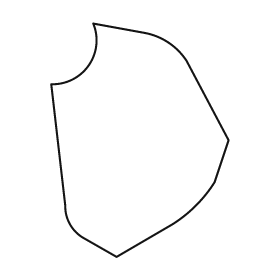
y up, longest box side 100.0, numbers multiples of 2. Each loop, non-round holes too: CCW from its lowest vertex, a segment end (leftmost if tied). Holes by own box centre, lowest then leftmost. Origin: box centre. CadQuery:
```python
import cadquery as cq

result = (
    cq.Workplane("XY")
    .moveTo(-10.0, -50.0)
    .lineTo(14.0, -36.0)
    .threePointArc((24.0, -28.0), (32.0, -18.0))
    .lineTo(38.0, 0.0)
    .lineTo(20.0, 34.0)
    .threePointArc((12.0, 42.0), (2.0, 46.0))
    .lineTo(-20.0, 50.0)
    .threePointArc((-22.0, 32.0), (-38.0, 24.0))
    .lineTo(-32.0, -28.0)
    .threePointArc((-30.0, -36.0), (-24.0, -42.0))
    .close()
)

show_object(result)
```